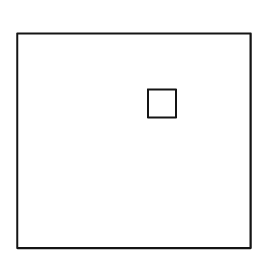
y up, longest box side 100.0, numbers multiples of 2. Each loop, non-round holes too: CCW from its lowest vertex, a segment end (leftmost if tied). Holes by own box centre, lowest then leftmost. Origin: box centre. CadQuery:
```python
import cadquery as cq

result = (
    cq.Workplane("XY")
    .moveTo(-50.0, -46.0)
    .lineTo(50.0, -46.0)
    .lineTo(50.0, 46.0)
    .lineTo(-50.0, 46.0)
    .close()
    .moveTo(6.0, 10.0)
    .lineTo(18.0, 10.0)
    .lineTo(18.0, 22.0)
    .lineTo(6.0, 22.0)
    .close()
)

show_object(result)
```